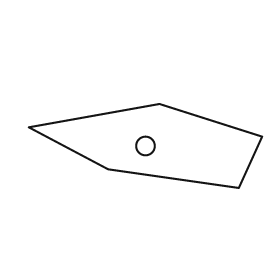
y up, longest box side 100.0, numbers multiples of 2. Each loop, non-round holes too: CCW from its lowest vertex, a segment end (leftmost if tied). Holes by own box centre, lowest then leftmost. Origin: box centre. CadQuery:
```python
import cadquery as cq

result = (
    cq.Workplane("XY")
    .moveTo(40.0, -18.0)
    .lineTo(50.0, 4.0)
    .lineTo(6.0, 18.0)
    .lineTo(-50.0, 8.0)
    .lineTo(-16.0, -10.0)
    .close()
    .moveTo(0.0, 0.0)
    .circle(4.0)
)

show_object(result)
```